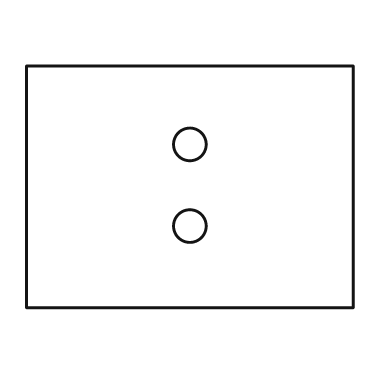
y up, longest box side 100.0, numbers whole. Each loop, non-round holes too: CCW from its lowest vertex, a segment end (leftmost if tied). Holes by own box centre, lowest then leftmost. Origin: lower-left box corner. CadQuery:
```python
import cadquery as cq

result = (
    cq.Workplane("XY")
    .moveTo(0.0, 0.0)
    .lineTo(100.0, 0.0)
    .lineTo(100.0, 74.0)
    .lineTo(0.0, 74.0)
    .close()
    .moveTo(50.0, 25.0)
    .circle(5.0)
    .moveTo(50.0, 50.0)
    .circle(5.0)
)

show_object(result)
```